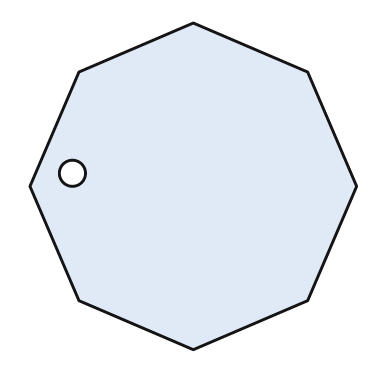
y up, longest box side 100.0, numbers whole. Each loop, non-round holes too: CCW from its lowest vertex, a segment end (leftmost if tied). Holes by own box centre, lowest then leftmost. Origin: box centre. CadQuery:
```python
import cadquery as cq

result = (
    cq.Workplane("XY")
    .moveTo(0.0, -50.0)
    .lineTo(35.0, -35.0)
    .lineTo(50.0, 0.0)
    .lineTo(35.0, 35.0)
    .lineTo(0.0, 50.0)
    .lineTo(-35.0, 35.0)
    .lineTo(-50.0, 0.0)
    .lineTo(-35.0, -35.0)
    .close()
    .moveTo(-37.0, 4.0)
    .circle(4.0)
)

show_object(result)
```